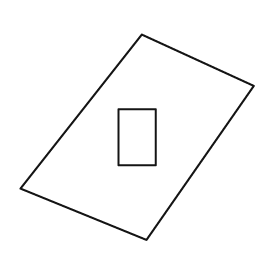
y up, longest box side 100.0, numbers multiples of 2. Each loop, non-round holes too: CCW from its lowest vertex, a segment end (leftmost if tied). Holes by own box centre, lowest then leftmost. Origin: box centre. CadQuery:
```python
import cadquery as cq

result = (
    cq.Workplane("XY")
    .moveTo(4.0, -44.0)
    .lineTo(50.0, 22.0)
    .lineTo(2.0, 44.0)
    .lineTo(-50.0, -22.0)
    .close()
    .moveTo(-8.0, -12.0)
    .lineTo(8.0, -12.0)
    .lineTo(8.0, 12.0)
    .lineTo(-8.0, 12.0)
    .close()
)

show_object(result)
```